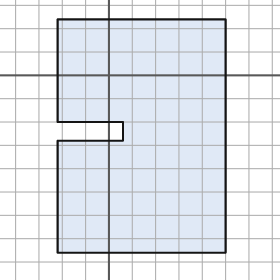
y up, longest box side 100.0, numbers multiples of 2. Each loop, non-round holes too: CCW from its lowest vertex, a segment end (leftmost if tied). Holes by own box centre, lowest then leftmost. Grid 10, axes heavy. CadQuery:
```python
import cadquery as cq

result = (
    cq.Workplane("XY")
    .moveTo(-22.0, -76.0)
    .lineTo(50.0, -76.0)
    .lineTo(50.0, 24.0)
    .lineTo(-22.0, 24.0)
    .lineTo(-22.0, -20.0)
    .lineTo(6.0, -20.0)
    .lineTo(6.0, -28.0)
    .lineTo(-22.0, -28.0)
    .close()
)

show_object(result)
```